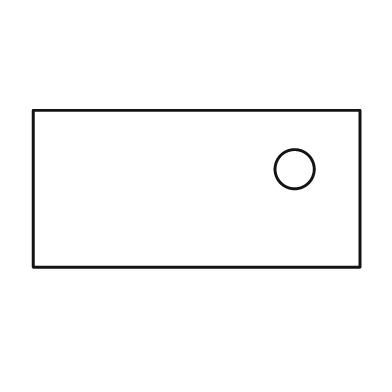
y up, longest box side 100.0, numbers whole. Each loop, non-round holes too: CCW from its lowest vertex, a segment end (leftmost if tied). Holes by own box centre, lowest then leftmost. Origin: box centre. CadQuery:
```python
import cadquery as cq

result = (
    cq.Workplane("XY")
    .moveTo(-50.0, -24.0)
    .lineTo(50.0, -24.0)
    .lineTo(50.0, 24.0)
    .lineTo(-50.0, 24.0)
    .close()
    .moveTo(30.0, 6.0)
    .circle(6.0)
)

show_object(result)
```